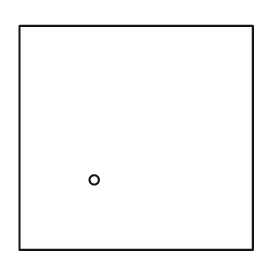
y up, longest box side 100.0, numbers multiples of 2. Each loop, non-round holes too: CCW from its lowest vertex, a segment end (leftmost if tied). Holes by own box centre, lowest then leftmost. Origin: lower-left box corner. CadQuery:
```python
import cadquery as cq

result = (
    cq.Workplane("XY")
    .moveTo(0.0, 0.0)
    .lineTo(100.0, 0.0)
    .lineTo(100.0, 96.0)
    .lineTo(0.0, 96.0)
    .close()
    .moveTo(32.0, 30.0)
    .circle(2.0)
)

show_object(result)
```